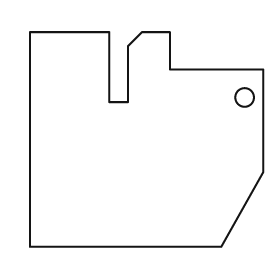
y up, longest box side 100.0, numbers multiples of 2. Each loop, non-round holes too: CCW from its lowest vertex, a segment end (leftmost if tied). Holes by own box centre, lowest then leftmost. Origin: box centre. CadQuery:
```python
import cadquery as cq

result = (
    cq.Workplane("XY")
    .moveTo(-50.0, -46.0)
    .lineTo(32.0, -46.0)
    .lineTo(50.0, -14.0)
    .lineTo(50.0, 30.0)
    .lineTo(10.0, 30.0)
    .lineTo(10.0, 46.0)
    .lineTo(-2.0, 46.0)
    .lineTo(-8.0, 40.0)
    .lineTo(-8.0, 16.0)
    .lineTo(-16.0, 16.0)
    .lineTo(-16.0, 46.0)
    .lineTo(-50.0, 46.0)
    .close()
    .moveTo(42.0, 18.0)
    .circle(4.0)
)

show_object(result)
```